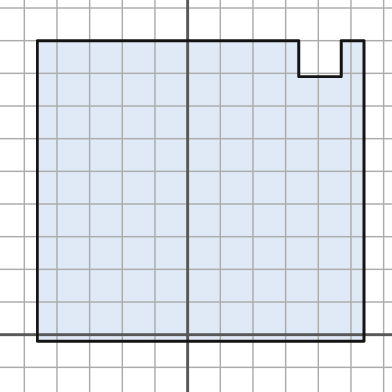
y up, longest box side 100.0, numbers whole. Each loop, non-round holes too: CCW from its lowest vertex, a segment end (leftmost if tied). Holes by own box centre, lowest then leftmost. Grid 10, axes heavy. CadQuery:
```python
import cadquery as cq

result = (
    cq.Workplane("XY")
    .moveTo(-46.0, -2.0)
    .lineTo(54.0, -2.0)
    .lineTo(54.0, 90.0)
    .lineTo(47.0, 90.0)
    .lineTo(47.0, 79.0)
    .lineTo(34.0, 79.0)
    .lineTo(34.0, 90.0)
    .lineTo(-46.0, 90.0)
    .close()
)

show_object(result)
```